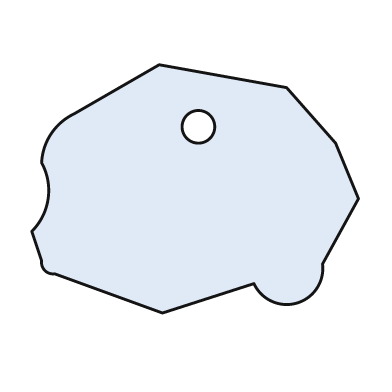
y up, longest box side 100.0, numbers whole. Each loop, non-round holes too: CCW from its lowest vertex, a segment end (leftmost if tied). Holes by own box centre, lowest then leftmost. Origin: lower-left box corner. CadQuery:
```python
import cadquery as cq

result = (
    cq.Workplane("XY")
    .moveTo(40.0, 0.0)
    .lineTo(68.0, 9.0)
    .threePointArc((81.0, 3.0), (89.0, 15.0))
    .lineTo(100.0, 35.0)
    .lineTo(93.0, 52.0)
    .lineTo(78.0, 69.0)
    .lineTo(39.0, 76.0)
    .lineTo(13.0, 61.0)
    .threePointArc((6.0, 55.0), (3.0, 46.0))
    .threePointArc((5.0, 35.0), (0.0, 25.0))
    .lineTo(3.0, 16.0)
    .threePointArc((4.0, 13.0), (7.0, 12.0))
    .close()
    .moveTo(51.0, 57.0)
    .circle(5.0)
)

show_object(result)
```